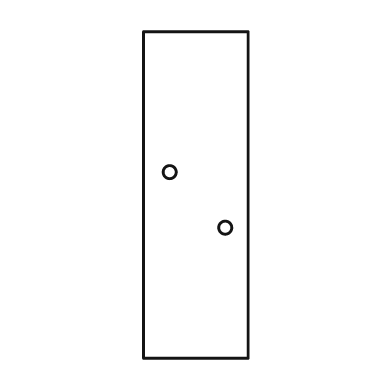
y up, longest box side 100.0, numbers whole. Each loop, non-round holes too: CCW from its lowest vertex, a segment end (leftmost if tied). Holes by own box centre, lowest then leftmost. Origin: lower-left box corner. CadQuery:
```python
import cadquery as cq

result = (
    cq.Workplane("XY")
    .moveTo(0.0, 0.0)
    .lineTo(32.0, 0.0)
    .lineTo(32.0, 100.0)
    .lineTo(0.0, 100.0)
    .close()
    .moveTo(25.0, 40.0)
    .circle(2.0)
    .moveTo(8.0, 57.0)
    .circle(2.0)
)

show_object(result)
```